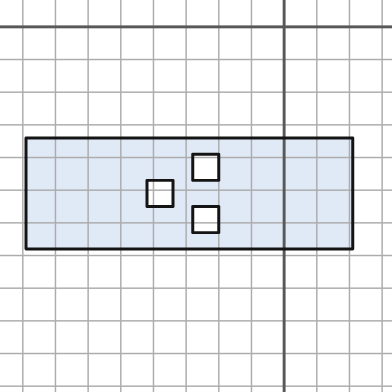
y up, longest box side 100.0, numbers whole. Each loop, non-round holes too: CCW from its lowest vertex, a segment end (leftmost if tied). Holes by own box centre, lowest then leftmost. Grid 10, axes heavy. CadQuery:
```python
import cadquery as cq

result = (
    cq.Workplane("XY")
    .moveTo(-79.0, -68.0)
    .lineTo(21.0, -68.0)
    .lineTo(21.0, -34.0)
    .lineTo(-79.0, -34.0)
    .close()
    .moveTo(-28.0, -63.0)
    .lineTo(-20.0, -63.0)
    .lineTo(-20.0, -55.0)
    .lineTo(-28.0, -55.0)
    .close()
    .moveTo(-42.0, -55.0)
    .lineTo(-34.0, -55.0)
    .lineTo(-34.0, -47.0)
    .lineTo(-42.0, -47.0)
    .close()
    .moveTo(-28.0, -47.0)
    .lineTo(-20.0, -47.0)
    .lineTo(-20.0, -39.0)
    .lineTo(-28.0, -39.0)
    .close()
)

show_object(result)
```